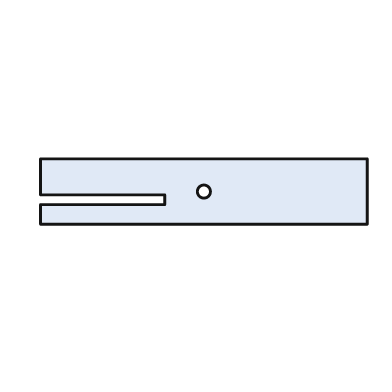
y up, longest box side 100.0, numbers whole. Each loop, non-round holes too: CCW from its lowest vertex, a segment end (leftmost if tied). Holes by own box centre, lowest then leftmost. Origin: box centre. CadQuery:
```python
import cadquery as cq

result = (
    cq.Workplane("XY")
    .moveTo(-50.0, -10.0)
    .lineTo(50.0, -10.0)
    .lineTo(50.0, 10.0)
    .lineTo(-50.0, 10.0)
    .lineTo(-50.0, -1.0)
    .lineTo(-12.0, -1.0)
    .lineTo(-12.0, -4.0)
    .lineTo(-50.0, -4.0)
    .close()
    .moveTo(0.0, 0.0)
    .circle(2.0)
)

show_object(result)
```